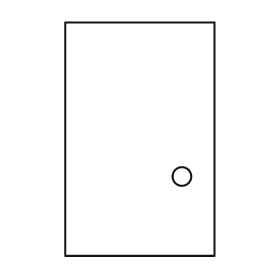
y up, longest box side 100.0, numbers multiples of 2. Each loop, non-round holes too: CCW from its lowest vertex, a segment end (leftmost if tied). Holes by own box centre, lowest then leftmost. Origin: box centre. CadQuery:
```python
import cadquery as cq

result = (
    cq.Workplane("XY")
    .moveTo(-32.0, -50.0)
    .lineTo(32.0, -50.0)
    .lineTo(32.0, 50.0)
    .lineTo(-32.0, 50.0)
    .close()
    .moveTo(18.0, -16.0)
    .circle(4.0)
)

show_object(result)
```